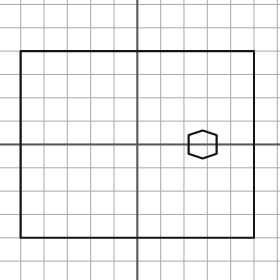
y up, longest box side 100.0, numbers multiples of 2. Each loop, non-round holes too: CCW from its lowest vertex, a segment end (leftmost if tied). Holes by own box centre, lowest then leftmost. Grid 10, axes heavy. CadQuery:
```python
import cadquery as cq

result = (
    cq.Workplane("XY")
    .moveTo(-50.0, -40.0)
    .lineTo(50.0, -40.0)
    .lineTo(50.0, 40.0)
    .lineTo(-50.0, 40.0)
    .close()
    .moveTo(28.0, -6.0)
    .lineTo(34.0, -4.0)
    .lineTo(34.0, 4.0)
    .lineTo(28.0, 6.0)
    .lineTo(22.0, 4.0)
    .lineTo(22.0, -4.0)
    .close()
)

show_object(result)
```